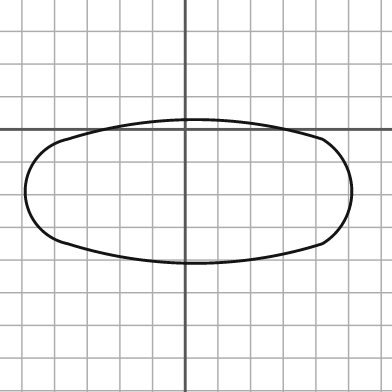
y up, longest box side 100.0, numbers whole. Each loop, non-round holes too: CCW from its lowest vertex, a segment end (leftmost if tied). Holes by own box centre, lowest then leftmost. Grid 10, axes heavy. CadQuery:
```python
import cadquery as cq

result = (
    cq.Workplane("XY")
    .moveTo(-36.0, -35.0)
    .threePointArc((3.0, -41.0), (42.0, -35.0))
    .threePointArc((51.0, -19.0), (42.0, -3.0))
    .threePointArc((3.0, 3.0), (-36.0, -3.0))
    .threePointArc((-49.0, -19.0), (-36.0, -35.0))
    .close()
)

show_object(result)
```